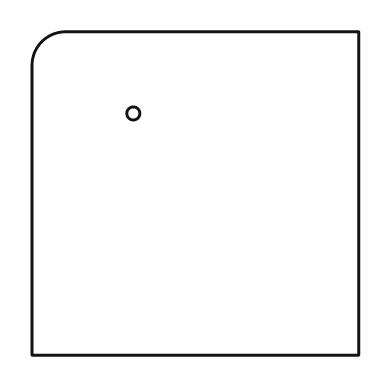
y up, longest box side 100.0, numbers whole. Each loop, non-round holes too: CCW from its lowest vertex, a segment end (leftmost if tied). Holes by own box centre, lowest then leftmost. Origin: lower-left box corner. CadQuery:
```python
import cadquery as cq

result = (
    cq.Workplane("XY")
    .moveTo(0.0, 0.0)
    .lineTo(100.0, 0.0)
    .lineTo(100.0, 99.0)
    .lineTo(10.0, 99.0)
    .threePointArc((3.0, 96.0), (0.0, 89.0))
    .close()
    .moveTo(31.0, 74.0)
    .circle(2.0)
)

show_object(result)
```